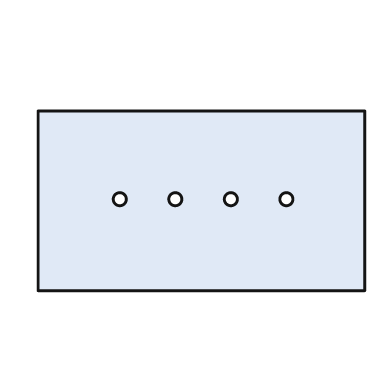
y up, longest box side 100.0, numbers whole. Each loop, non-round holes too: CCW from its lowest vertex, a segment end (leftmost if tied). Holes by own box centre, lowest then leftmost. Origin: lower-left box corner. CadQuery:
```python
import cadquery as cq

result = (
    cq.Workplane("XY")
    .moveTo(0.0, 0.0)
    .lineTo(100.0, 0.0)
    .lineTo(100.0, 55.0)
    .lineTo(0.0, 55.0)
    .close()
    .moveTo(25.0, 28.0)
    .circle(2.0)
    .moveTo(42.0, 28.0)
    .circle(2.0)
    .moveTo(59.0, 28.0)
    .circle(2.0)
    .moveTo(76.0, 28.0)
    .circle(2.0)
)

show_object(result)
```